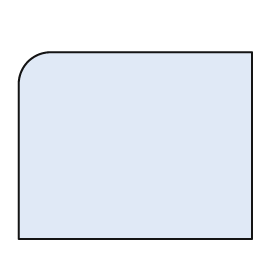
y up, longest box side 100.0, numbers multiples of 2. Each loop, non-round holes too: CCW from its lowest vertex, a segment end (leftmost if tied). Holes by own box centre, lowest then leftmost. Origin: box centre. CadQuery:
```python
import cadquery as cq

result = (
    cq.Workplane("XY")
    .moveTo(-50.0, -40.0)
    .lineTo(50.0, -40.0)
    .lineTo(50.0, 40.0)
    .lineTo(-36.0, 40.0)
    .threePointArc((-46.0, 36.0), (-50.0, 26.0))
    .close()
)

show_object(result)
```